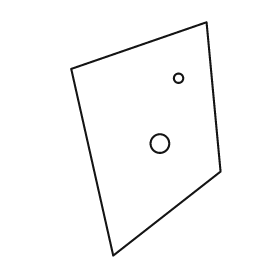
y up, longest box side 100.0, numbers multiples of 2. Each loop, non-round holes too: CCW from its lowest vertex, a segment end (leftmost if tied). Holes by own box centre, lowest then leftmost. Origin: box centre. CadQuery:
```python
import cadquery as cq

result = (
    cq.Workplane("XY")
    .moveTo(-14.0, -50.0)
    .lineTo(32.0, -14.0)
    .lineTo(26.0, 50.0)
    .lineTo(-32.0, 30.0)
    .close()
    .moveTo(6.0, -2.0)
    .circle(4.0)
    .moveTo(14.0, 26.0)
    .circle(2.0)
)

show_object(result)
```